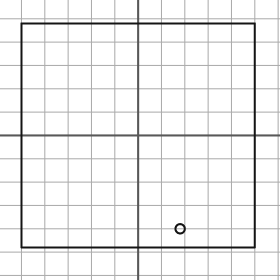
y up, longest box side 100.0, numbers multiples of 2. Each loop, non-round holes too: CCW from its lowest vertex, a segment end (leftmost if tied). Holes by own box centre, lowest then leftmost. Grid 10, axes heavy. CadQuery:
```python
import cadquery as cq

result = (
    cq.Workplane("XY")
    .moveTo(-50.0, -48.0)
    .lineTo(50.0, -48.0)
    .lineTo(50.0, 48.0)
    .lineTo(-50.0, 48.0)
    .close()
    .moveTo(18.0, -40.0)
    .circle(2.0)
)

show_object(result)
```